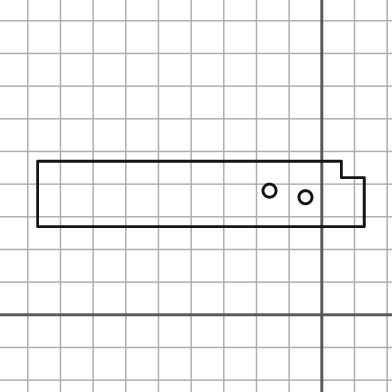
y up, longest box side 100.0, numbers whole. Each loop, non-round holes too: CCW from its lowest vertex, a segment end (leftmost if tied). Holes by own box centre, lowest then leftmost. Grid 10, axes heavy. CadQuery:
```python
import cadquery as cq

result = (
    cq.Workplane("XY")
    .moveTo(-87.0, 27.0)
    .lineTo(13.0, 27.0)
    .lineTo(13.0, 42.0)
    .lineTo(6.0, 42.0)
    .lineTo(6.0, 47.0)
    .lineTo(-87.0, 47.0)
    .close()
    .moveTo(-5.0, 36.0)
    .circle(2.0)
    .moveTo(-16.0, 38.0)
    .circle(2.0)
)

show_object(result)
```